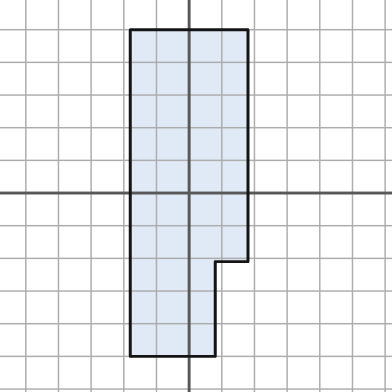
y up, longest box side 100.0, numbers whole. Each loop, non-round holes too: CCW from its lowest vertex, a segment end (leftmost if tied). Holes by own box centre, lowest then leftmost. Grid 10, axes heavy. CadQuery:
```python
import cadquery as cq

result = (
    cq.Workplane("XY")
    .moveTo(-18.0, -50.0)
    .lineTo(8.0, -50.0)
    .lineTo(8.0, -21.0)
    .lineTo(18.0, -21.0)
    .lineTo(18.0, 50.0)
    .lineTo(-18.0, 50.0)
    .close()
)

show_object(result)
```